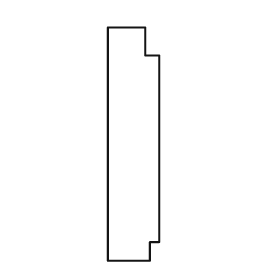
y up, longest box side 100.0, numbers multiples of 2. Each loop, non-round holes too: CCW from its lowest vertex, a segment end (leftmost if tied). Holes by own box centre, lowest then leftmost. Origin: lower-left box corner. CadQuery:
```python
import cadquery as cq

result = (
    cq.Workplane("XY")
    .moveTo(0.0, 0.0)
    .lineTo(18.0, 0.0)
    .lineTo(18.0, 8.0)
    .lineTo(22.0, 8.0)
    .lineTo(22.0, 88.0)
    .lineTo(16.0, 88.0)
    .lineTo(16.0, 100.0)
    .lineTo(0.0, 100.0)
    .close()
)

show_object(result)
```